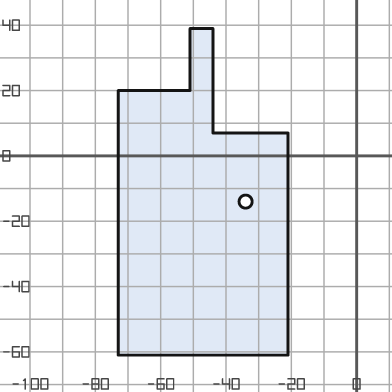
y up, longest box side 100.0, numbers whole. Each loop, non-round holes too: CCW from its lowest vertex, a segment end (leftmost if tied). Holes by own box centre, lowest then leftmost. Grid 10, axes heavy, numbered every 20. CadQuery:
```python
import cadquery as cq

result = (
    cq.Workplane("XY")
    .moveTo(-73.0, -61.0)
    .lineTo(-21.0, -61.0)
    .lineTo(-21.0, 7.0)
    .lineTo(-44.0, 7.0)
    .lineTo(-44.0, 39.0)
    .lineTo(-51.0, 39.0)
    .lineTo(-51.0, 20.0)
    .lineTo(-73.0, 20.0)
    .close()
    .moveTo(-34.0, -14.0)
    .circle(2.0)
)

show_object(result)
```